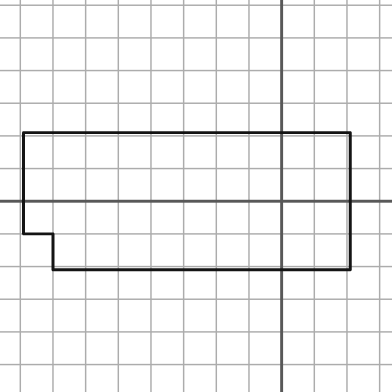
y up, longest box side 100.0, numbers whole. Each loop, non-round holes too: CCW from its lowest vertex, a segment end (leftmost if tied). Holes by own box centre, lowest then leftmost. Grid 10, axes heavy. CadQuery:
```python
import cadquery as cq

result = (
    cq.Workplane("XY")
    .moveTo(-70.0, -21.0)
    .lineTo(21.0, -21.0)
    .lineTo(21.0, 21.0)
    .lineTo(-79.0, 21.0)
    .lineTo(-79.0, -10.0)
    .lineTo(-70.0, -10.0)
    .close()
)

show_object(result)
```